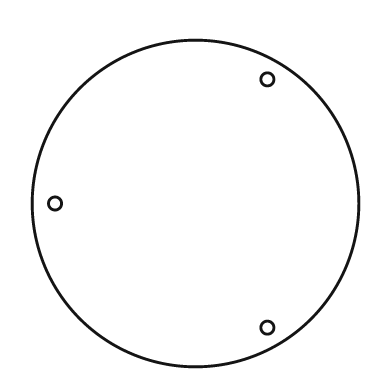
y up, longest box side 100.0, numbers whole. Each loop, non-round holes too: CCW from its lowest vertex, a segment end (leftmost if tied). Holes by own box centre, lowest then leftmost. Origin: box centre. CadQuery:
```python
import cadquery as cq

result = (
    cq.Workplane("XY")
    .moveTo(0.0, 0.0)
    .circle(50.0)
    .moveTo(22.0, -38.0)
    .circle(2.0)
    .moveTo(-43.0, 0.0)
    .circle(2.0)
    .moveTo(22.0, 38.0)
    .circle(2.0)
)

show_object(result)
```